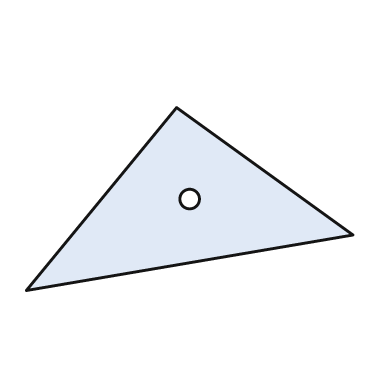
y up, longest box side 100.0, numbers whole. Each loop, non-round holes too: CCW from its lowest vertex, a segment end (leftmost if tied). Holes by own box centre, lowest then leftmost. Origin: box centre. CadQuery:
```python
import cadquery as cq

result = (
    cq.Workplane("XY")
    .moveTo(-50.0, -28.0)
    .lineTo(50.0, -11.0)
    .lineTo(-4.0, 28.0)
    .close()
    .moveTo(0.0, 0.0)
    .circle(3.0)
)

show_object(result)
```